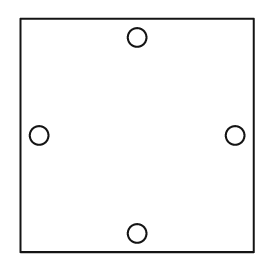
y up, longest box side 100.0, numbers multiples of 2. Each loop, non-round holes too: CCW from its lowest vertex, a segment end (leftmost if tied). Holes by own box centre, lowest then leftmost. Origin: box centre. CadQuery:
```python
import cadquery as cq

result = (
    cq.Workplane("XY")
    .moveTo(-50.0, -50.0)
    .lineTo(50.0, -50.0)
    .lineTo(50.0, 50.0)
    .lineTo(-50.0, 50.0)
    .close()
    .moveTo(0.0, -42.0)
    .circle(4.0)
    .moveTo(-42.0, 0.0)
    .circle(4.0)
    .moveTo(42.0, 0.0)
    .circle(4.0)
    .moveTo(0.0, 42.0)
    .circle(4.0)
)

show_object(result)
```